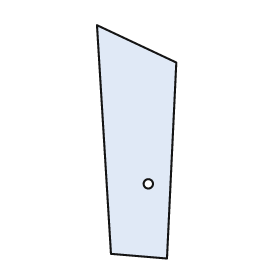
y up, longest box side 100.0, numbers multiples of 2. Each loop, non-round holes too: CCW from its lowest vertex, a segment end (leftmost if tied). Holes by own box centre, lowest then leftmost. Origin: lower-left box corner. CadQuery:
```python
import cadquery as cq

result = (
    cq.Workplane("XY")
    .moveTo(30.0, 0.0)
    .lineTo(34.0, 84.0)
    .lineTo(0.0, 100.0)
    .lineTo(6.0, 2.0)
    .close()
    .moveTo(22.0, 32.0)
    .circle(2.0)
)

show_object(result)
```